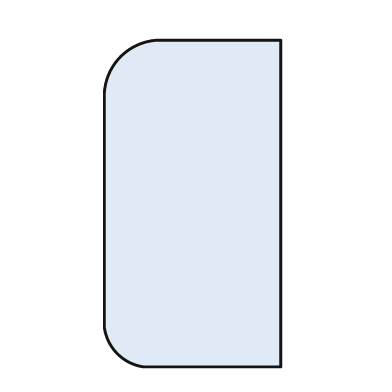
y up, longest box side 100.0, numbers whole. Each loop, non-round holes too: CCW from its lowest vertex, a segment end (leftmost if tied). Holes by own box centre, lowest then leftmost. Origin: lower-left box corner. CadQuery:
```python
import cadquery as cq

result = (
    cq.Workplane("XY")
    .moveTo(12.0, 0.0)
    .lineTo(54.0, 0.0)
    .lineTo(54.0, 100.0)
    .lineTo(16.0, 100.0)
    .threePointArc((5.0, 95.0), (0.0, 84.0))
    .lineTo(0.0, 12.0)
    .threePointArc((4.0, 4.0), (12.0, 0.0))
    .close()
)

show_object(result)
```